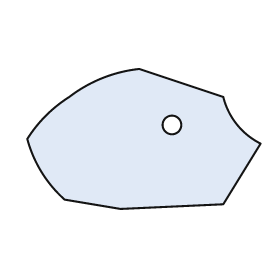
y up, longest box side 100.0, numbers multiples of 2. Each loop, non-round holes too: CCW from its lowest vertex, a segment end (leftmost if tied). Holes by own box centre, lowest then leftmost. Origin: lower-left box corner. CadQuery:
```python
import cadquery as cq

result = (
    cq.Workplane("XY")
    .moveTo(40.0, 0.0)
    .lineTo(84.0, 2.0)
    .lineTo(100.0, 28.0)
    .threePointArc((90.0, 36.0), (84.0, 48.0))
    .lineTo(48.0, 60.0)
    .threePointArc((32.0, 56.0), (18.0, 48.0))
    .threePointArc((8.0, 40.0), (0.0, 30.0))
    .threePointArc((6.0, 16.0), (16.0, 4.0))
    .close()
    .moveTo(62.0, 36.0)
    .circle(4.0)
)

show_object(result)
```